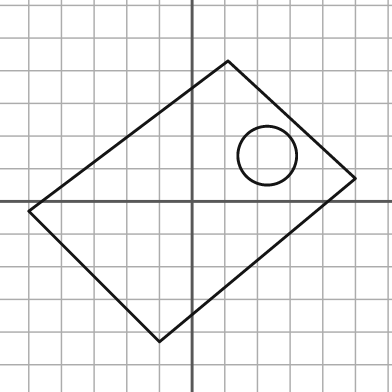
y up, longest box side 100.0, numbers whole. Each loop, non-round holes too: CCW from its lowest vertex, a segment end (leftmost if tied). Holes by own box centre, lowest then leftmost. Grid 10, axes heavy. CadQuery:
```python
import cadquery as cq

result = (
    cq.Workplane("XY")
    .moveTo(-10.0, -43.0)
    .lineTo(50.0, 7.0)
    .lineTo(11.0, 43.0)
    .lineTo(-50.0, -3.0)
    .close()
    .moveTo(23.0, 14.0)
    .circle(9.0)
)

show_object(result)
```